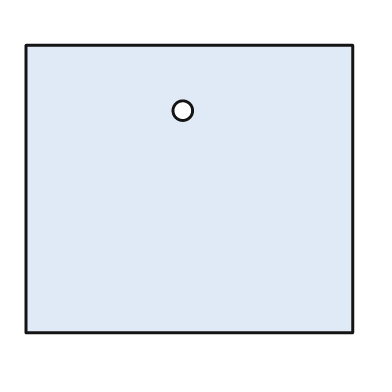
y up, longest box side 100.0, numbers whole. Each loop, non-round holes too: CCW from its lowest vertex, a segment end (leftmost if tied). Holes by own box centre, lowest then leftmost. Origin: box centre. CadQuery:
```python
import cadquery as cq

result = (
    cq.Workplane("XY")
    .moveTo(-50.0, -44.0)
    .lineTo(50.0, -44.0)
    .lineTo(50.0, 44.0)
    .lineTo(-50.0, 44.0)
    .close()
    .moveTo(-2.0, 24.0)
    .circle(3.0)
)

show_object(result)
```